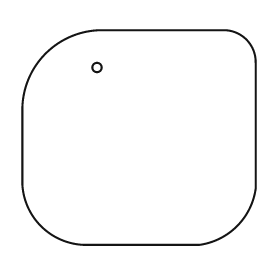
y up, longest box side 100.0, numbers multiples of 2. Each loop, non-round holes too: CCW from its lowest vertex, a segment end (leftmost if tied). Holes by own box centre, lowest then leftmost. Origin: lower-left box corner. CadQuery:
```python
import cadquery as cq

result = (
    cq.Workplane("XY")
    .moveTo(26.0, 0.0)
    .lineTo(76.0, 0.0)
    .threePointArc((92.0, 8.0), (100.0, 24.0))
    .lineTo(100.0, 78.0)
    .threePointArc((96.0, 88.0), (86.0, 92.0))
    .lineTo(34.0, 92.0)
    .threePointArc((10.0, 82.0), (0.0, 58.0))
    .lineTo(0.0, 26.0)
    .threePointArc((8.0, 8.0), (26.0, 0.0))
    .close()
    .moveTo(32.0, 76.0)
    .circle(2.0)
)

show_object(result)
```